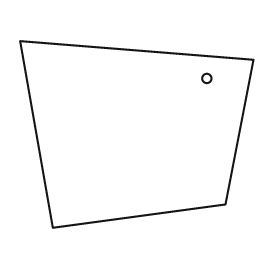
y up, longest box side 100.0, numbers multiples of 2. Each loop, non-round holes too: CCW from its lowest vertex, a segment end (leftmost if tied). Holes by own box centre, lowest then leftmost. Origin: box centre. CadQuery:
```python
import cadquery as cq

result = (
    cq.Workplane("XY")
    .moveTo(-36.0, -40.0)
    .lineTo(38.0, -30.0)
    .lineTo(50.0, 32.0)
    .lineTo(-50.0, 40.0)
    .close()
    .moveTo(30.0, 24.0)
    .circle(2.0)
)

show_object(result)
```